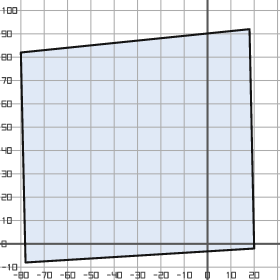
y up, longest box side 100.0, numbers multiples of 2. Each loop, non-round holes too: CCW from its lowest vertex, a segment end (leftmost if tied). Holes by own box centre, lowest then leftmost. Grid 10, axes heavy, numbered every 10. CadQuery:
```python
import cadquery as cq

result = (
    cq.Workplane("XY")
    .moveTo(-78.0, -8.0)
    .lineTo(20.0, -2.0)
    .lineTo(18.0, 92.0)
    .lineTo(-80.0, 82.0)
    .close()
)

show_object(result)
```